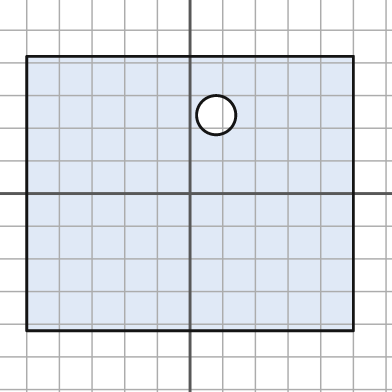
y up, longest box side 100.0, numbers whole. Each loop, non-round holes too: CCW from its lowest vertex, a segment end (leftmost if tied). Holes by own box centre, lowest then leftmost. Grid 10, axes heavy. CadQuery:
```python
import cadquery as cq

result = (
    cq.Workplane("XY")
    .moveTo(-50.0, -42.0)
    .lineTo(50.0, -42.0)
    .lineTo(50.0, 42.0)
    .lineTo(-50.0, 42.0)
    .close()
    .moveTo(8.0, 24.0)
    .circle(6.0)
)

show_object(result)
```